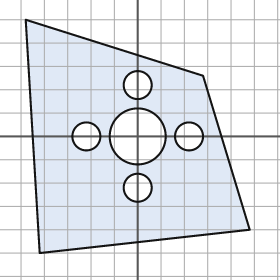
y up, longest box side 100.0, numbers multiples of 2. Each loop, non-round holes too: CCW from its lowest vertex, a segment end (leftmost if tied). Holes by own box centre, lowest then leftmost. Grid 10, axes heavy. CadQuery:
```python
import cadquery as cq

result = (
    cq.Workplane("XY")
    .moveTo(-42.0, -50.0)
    .lineTo(48.0, -40.0)
    .lineTo(28.0, 26.0)
    .lineTo(-48.0, 50.0)
    .close()
    .moveTo(0.0, -22.0)
    .circle(6.0)
    .moveTo(-22.0, 0.0)
    .circle(6.0)
    .moveTo(0.0, 0.0)
    .circle(12.0)
    .moveTo(22.0, 0.0)
    .circle(6.0)
    .moveTo(0.0, 22.0)
    .circle(6.0)
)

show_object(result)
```